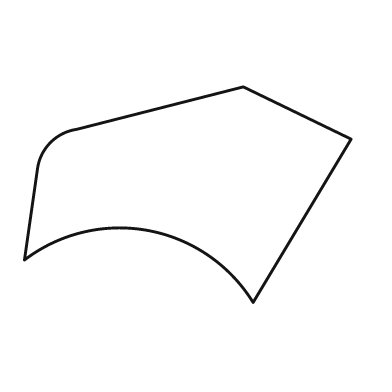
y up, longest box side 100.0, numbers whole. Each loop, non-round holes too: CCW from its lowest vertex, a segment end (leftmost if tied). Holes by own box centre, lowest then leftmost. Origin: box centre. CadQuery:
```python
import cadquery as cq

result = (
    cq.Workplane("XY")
    .moveTo(20.0, -33.0)
    .lineTo(50.0, 17.0)
    .lineTo(17.0, 33.0)
    .lineTo(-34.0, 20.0)
    .threePointArc((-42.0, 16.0), (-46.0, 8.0))
    .lineTo(-50.0, -20.0)
    .threePointArc((-12.0, -11.0), (20.0, -33.0))
    .close()
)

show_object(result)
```